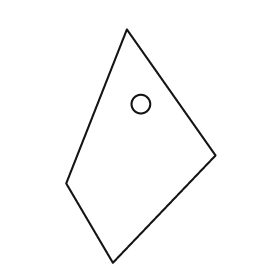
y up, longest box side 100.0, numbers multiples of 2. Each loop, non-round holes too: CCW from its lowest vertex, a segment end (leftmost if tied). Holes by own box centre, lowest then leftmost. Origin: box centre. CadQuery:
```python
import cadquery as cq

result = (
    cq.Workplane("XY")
    .moveTo(-12.0, -50.0)
    .lineTo(32.0, -4.0)
    .lineTo(-6.0, 50.0)
    .lineTo(-32.0, -16.0)
    .close()
    .moveTo(0.0, 18.0)
    .circle(4.0)
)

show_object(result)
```